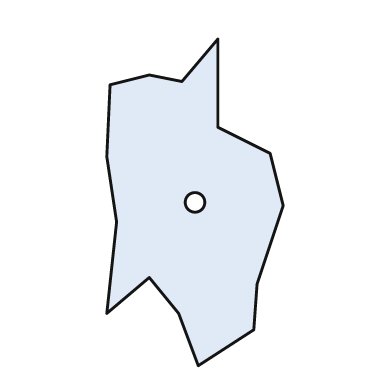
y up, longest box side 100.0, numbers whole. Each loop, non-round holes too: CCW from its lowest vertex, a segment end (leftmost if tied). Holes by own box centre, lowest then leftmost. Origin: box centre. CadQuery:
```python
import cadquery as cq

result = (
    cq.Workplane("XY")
    .moveTo(1.0, -50.0)
    .lineTo(18.0, -39.0)
    .lineTo(19.0, -25.0)
    .lineTo(27.0, -1.0)
    .lineTo(23.0, 15.0)
    .lineTo(7.0, 23.0)
    .lineTo(7.0, 50.0)
    .lineTo(-4.0, 37.0)
    .lineTo(-14.0, 39.0)
    .lineTo(-26.0, 36.0)
    .lineTo(-27.0, 14.0)
    .lineTo(-24.0, -6.0)
    .lineTo(-27.0, -34.0)
    .lineTo(-14.0, -23.0)
    .lineTo(-5.0, -34.0)
    .close()
    .moveTo(0.0, 0.0)
    .circle(3.0)
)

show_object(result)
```